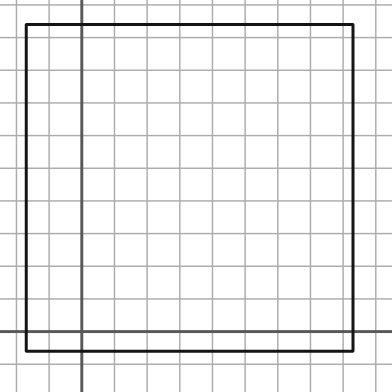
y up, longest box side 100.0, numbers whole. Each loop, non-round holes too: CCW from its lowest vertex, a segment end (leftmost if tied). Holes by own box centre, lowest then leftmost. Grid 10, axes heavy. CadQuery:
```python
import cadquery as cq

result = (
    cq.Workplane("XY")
    .moveTo(-17.0, -6.0)
    .lineTo(83.0, -6.0)
    .lineTo(83.0, 94.0)
    .lineTo(-17.0, 94.0)
    .close()
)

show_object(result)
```